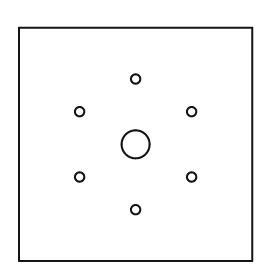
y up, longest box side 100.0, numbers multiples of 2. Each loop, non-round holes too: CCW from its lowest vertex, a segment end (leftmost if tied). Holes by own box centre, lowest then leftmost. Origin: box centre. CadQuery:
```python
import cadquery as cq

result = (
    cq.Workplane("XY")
    .moveTo(-50.0, -50.0)
    .lineTo(50.0, -50.0)
    .lineTo(50.0, 50.0)
    .lineTo(-50.0, 50.0)
    .close()
    .moveTo(0.0, -28.0)
    .circle(2.0)
    .moveTo(-24.0, -14.0)
    .circle(2.0)
    .moveTo(24.0, -14.0)
    .circle(2.0)
    .moveTo(0.0, 0.0)
    .circle(6.0)
    .moveTo(-24.0, 14.0)
    .circle(2.0)
    .moveTo(24.0, 14.0)
    .circle(2.0)
    .moveTo(0.0, 28.0)
    .circle(2.0)
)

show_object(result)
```